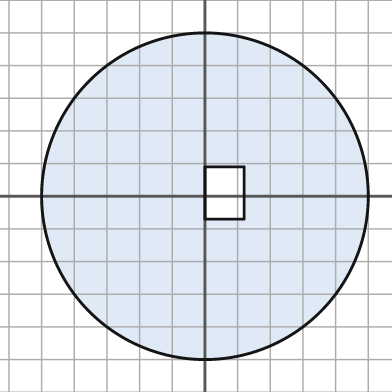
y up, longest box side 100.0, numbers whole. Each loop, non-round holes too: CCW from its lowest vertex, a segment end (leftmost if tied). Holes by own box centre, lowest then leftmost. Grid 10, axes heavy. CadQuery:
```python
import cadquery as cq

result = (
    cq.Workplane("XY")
    .moveTo(0.0, 0.0)
    .circle(50.0)
    .moveTo(0.0, -7.0)
    .lineTo(12.0, -7.0)
    .lineTo(12.0, 9.0)
    .lineTo(0.0, 9.0)
    .close()
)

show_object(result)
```